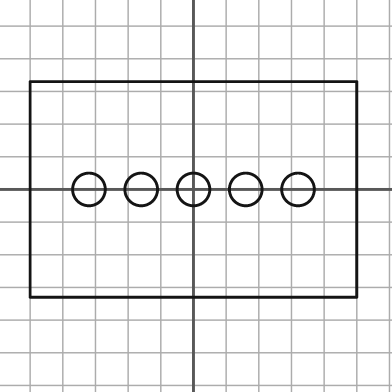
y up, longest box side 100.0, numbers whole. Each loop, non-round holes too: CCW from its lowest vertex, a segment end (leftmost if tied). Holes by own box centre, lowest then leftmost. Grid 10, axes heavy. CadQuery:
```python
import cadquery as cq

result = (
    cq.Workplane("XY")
    .moveTo(-50.0, -33.0)
    .lineTo(50.0, -33.0)
    .lineTo(50.0, 33.0)
    .lineTo(-50.0, 33.0)
    .close()
    .moveTo(-32.0, 0.0)
    .circle(5.0)
    .moveTo(-16.0, 0.0)
    .circle(5.0)
    .moveTo(0.0, 0.0)
    .circle(5.0)
    .moveTo(16.0, 0.0)
    .circle(5.0)
    .moveTo(32.0, 0.0)
    .circle(5.0)
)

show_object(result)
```